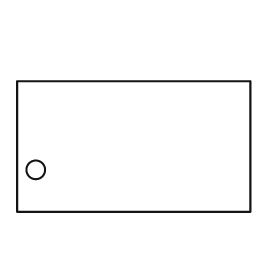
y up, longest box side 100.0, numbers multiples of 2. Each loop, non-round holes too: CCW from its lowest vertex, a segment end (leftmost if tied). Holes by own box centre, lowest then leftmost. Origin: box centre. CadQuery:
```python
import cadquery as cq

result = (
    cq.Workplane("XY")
    .moveTo(-50.0, -28.0)
    .lineTo(50.0, -28.0)
    .lineTo(50.0, 28.0)
    .lineTo(-50.0, 28.0)
    .close()
    .moveTo(-42.0, -10.0)
    .circle(4.0)
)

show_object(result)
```